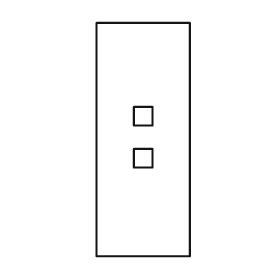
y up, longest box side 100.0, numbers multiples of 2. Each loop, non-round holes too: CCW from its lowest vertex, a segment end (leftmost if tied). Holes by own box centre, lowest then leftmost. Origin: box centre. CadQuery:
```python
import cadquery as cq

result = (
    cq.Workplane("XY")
    .moveTo(-20.0, -50.0)
    .lineTo(20.0, -50.0)
    .lineTo(20.0, 50.0)
    .lineTo(-20.0, 50.0)
    .close()
    .moveTo(-4.0, -12.0)
    .lineTo(4.0, -12.0)
    .lineTo(4.0, -4.0)
    .lineTo(-4.0, -4.0)
    .close()
    .moveTo(-4.0, 6.0)
    .lineTo(4.0, 6.0)
    .lineTo(4.0, 14.0)
    .lineTo(-4.0, 14.0)
    .close()
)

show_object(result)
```